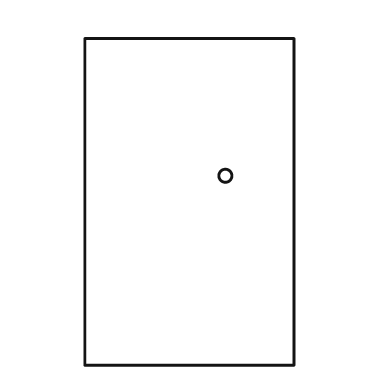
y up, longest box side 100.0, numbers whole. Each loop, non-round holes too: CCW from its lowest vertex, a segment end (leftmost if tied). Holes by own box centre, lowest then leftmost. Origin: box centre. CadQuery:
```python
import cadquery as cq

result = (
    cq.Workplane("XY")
    .moveTo(-32.0, -50.0)
    .lineTo(32.0, -50.0)
    .lineTo(32.0, 50.0)
    .lineTo(-32.0, 50.0)
    .close()
    .moveTo(11.0, 8.0)
    .circle(2.0)
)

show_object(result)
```